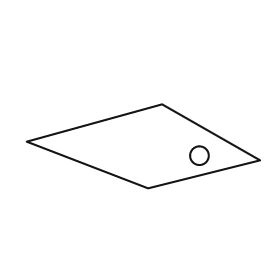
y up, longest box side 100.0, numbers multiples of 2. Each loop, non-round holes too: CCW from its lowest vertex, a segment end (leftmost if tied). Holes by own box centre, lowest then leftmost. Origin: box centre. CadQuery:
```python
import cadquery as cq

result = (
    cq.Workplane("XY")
    .moveTo(2.0, -18.0)
    .lineTo(50.0, -6.0)
    .lineTo(8.0, 18.0)
    .lineTo(-50.0, 2.0)
    .close()
    .moveTo(24.0, -4.0)
    .circle(4.0)
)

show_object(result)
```